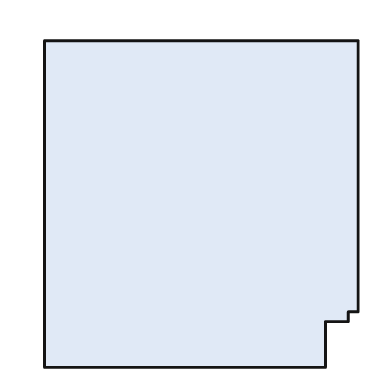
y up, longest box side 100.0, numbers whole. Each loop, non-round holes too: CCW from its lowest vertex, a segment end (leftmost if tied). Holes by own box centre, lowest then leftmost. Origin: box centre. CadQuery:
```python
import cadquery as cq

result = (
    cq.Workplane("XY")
    .moveTo(-48.0, -50.0)
    .lineTo(38.0, -50.0)
    .lineTo(38.0, -36.0)
    .lineTo(45.0, -36.0)
    .lineTo(45.0, -33.0)
    .lineTo(48.0, -33.0)
    .lineTo(48.0, 50.0)
    .lineTo(-48.0, 50.0)
    .close()
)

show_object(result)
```